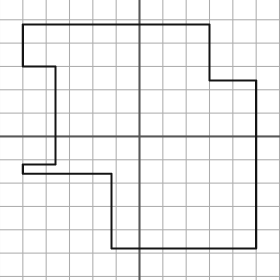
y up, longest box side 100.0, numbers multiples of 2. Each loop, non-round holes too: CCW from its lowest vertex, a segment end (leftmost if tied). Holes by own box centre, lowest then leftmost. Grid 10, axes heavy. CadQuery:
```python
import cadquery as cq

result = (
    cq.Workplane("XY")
    .moveTo(-12.0, -48.0)
    .lineTo(50.0, -48.0)
    .lineTo(50.0, 24.0)
    .lineTo(30.0, 24.0)
    .lineTo(30.0, 48.0)
    .lineTo(-50.0, 48.0)
    .lineTo(-50.0, 30.0)
    .lineTo(-36.0, 30.0)
    .lineTo(-36.0, -12.0)
    .lineTo(-50.0, -12.0)
    .lineTo(-50.0, -16.0)
    .lineTo(-12.0, -16.0)
    .close()
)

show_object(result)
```